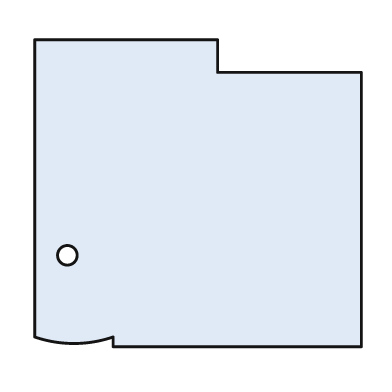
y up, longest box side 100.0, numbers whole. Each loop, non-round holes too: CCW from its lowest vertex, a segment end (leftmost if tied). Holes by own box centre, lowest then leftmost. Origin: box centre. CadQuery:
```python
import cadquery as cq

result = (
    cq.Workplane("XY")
    .moveTo(-26.0, -47.0)
    .lineTo(50.0, -47.0)
    .lineTo(50.0, 37.0)
    .lineTo(6.0, 37.0)
    .lineTo(6.0, 47.0)
    .lineTo(-50.0, 47.0)
    .lineTo(-50.0, -44.0)
    .threePointArc((-38.0, -46.0), (-26.0, -44.0))
    .close()
    .moveTo(-40.0, -19.0)
    .circle(3.0)
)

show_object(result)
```